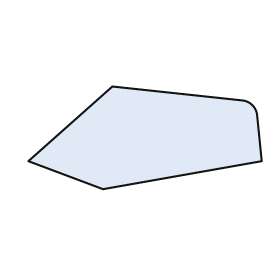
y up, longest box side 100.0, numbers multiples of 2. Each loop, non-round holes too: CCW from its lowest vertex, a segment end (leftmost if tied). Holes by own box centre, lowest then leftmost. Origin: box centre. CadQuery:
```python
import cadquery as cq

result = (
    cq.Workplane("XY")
    .moveTo(-18.0, -22.0)
    .lineTo(50.0, -10.0)
    .lineTo(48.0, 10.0)
    .threePointArc((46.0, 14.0), (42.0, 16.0))
    .lineTo(-14.0, 22.0)
    .lineTo(-50.0, -10.0)
    .close()
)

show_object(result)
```